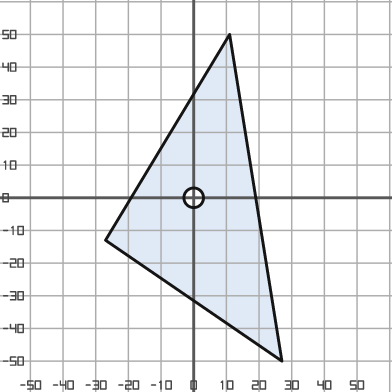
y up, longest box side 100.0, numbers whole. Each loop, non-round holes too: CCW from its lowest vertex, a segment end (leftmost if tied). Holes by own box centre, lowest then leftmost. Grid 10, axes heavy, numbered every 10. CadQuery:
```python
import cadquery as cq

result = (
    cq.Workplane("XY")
    .moveTo(27.0, -50.0)
    .lineTo(11.0, 50.0)
    .lineTo(-27.0, -13.0)
    .close()
    .moveTo(0.0, 0.0)
    .circle(3.0)
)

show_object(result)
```